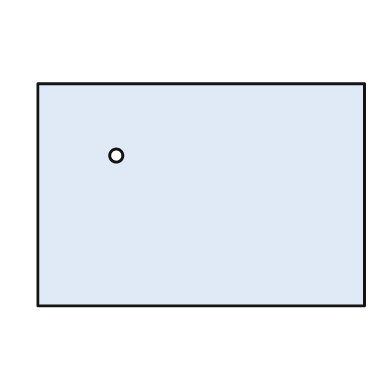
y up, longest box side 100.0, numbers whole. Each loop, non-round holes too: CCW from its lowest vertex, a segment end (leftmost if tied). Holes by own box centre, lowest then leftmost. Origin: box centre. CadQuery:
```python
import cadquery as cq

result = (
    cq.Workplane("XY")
    .moveTo(-50.0, -34.0)
    .lineTo(50.0, -34.0)
    .lineTo(50.0, 34.0)
    .lineTo(-50.0, 34.0)
    .close()
    .moveTo(-26.0, 12.0)
    .circle(2.0)
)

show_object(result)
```